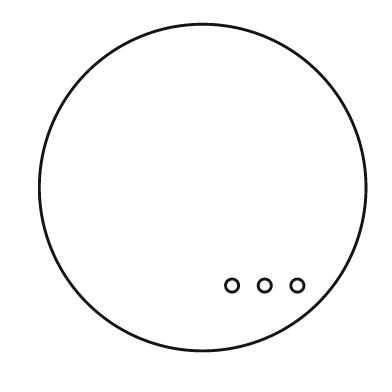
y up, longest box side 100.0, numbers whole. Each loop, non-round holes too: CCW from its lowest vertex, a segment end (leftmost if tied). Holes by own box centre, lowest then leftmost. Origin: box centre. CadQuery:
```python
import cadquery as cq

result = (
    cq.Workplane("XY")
    .moveTo(0.0, 0.0)
    .circle(50.0)
    .moveTo(9.0, -30.0)
    .circle(2.0)
    .moveTo(19.0, -30.0)
    .circle(2.0)
    .moveTo(29.0, -30.0)
    .circle(2.0)
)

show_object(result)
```